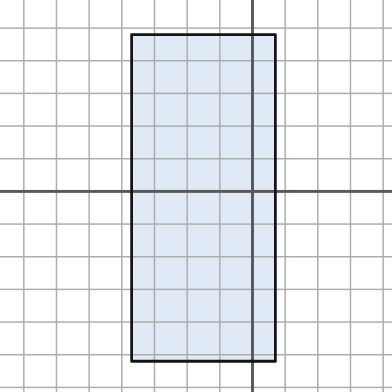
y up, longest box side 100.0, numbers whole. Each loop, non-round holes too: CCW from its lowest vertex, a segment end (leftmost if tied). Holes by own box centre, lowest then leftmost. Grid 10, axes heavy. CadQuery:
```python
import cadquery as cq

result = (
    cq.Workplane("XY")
    .moveTo(-37.0, -52.0)
    .lineTo(7.0, -52.0)
    .lineTo(7.0, 48.0)
    .lineTo(-37.0, 48.0)
    .close()
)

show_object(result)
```